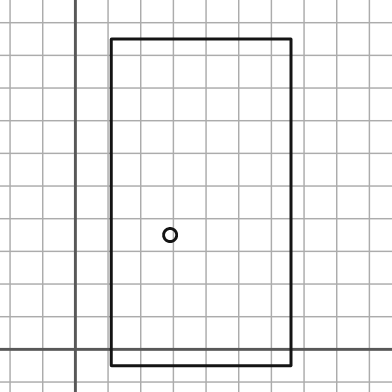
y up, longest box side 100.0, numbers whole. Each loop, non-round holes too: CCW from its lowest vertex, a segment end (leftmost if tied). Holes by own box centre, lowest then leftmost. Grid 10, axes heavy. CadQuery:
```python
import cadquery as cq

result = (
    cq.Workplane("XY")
    .moveTo(11.0, -5.0)
    .lineTo(66.0, -5.0)
    .lineTo(66.0, 95.0)
    .lineTo(11.0, 95.0)
    .close()
    .moveTo(29.0, 35.0)
    .circle(2.0)
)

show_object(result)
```